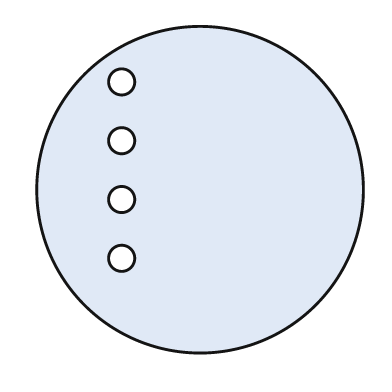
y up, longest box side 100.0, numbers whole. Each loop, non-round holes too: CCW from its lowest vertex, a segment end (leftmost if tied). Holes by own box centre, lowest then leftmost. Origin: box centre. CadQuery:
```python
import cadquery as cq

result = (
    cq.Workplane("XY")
    .moveTo(0.0, 0.0)
    .circle(50.0)
    .moveTo(-24.0, -21.0)
    .circle(4.0)
    .moveTo(-24.0, -3.0)
    .circle(4.0)
    .moveTo(-24.0, 15.0)
    .circle(4.0)
    .moveTo(-24.0, 33.0)
    .circle(4.0)
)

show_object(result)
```